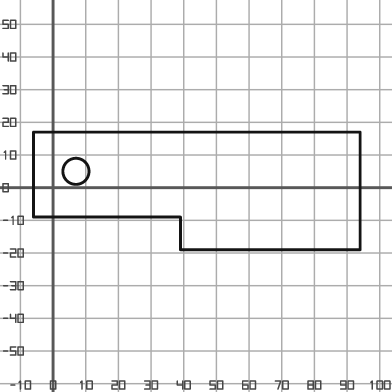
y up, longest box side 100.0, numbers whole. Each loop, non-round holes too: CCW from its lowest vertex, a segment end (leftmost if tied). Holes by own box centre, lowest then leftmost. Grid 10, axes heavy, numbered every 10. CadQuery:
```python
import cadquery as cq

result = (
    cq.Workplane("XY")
    .moveTo(39.0, -19.0)
    .lineTo(94.0, -19.0)
    .lineTo(94.0, 17.0)
    .lineTo(-6.0, 17.0)
    .lineTo(-6.0, -9.0)
    .lineTo(39.0, -9.0)
    .close()
    .moveTo(7.0, 5.0)
    .circle(4.0)
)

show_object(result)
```